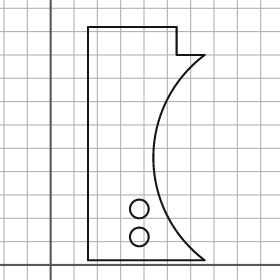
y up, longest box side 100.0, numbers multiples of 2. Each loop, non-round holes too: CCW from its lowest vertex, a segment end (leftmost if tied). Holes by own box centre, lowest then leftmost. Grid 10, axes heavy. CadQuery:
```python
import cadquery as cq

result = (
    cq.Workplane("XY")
    .moveTo(16.0, 2.0)
    .lineTo(66.0, 2.0)
    .threePointArc((44.0, 46.0), (66.0, 90.0))
    .lineTo(54.0, 90.0)
    .lineTo(54.0, 102.0)
    .lineTo(16.0, 102.0)
    .close()
    .moveTo(38.0, 12.0)
    .circle(4.0)
    .moveTo(38.0, 24.0)
    .circle(4.0)
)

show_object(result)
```